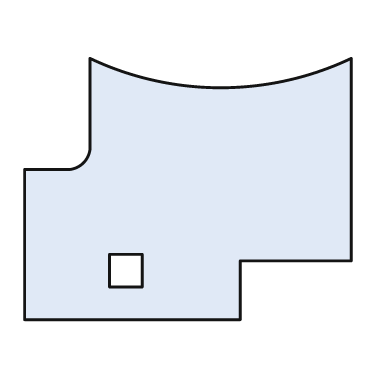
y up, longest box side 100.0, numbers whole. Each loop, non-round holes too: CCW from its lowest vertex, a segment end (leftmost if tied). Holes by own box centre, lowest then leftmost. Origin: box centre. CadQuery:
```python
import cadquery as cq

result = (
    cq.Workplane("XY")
    .moveTo(-50.0, -40.0)
    .lineTo(16.0, -40.0)
    .lineTo(16.0, -22.0)
    .lineTo(50.0, -22.0)
    .lineTo(50.0, 40.0)
    .threePointArc((10.0, 31.0), (-30.0, 40.0))
    .lineTo(-30.0, 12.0)
    .threePointArc((-32.0, 8.0), (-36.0, 6.0))
    .lineTo(-50.0, 6.0)
    .close()
    .moveTo(-24.0, -30.0)
    .lineTo(-14.0, -30.0)
    .lineTo(-14.0, -20.0)
    .lineTo(-24.0, -20.0)
    .close()
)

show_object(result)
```